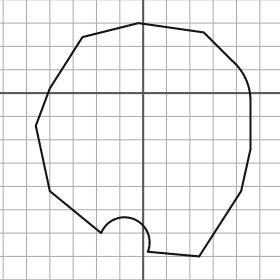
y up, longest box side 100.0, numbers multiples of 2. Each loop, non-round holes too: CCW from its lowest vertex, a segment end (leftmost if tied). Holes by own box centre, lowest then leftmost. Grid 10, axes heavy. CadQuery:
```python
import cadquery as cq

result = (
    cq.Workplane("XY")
    .moveTo(24.0, -70.0)
    .lineTo(42.0, -42.0)
    .lineTo(46.0, -24.0)
    .lineTo(46.0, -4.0)
    .threePointArc((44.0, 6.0), (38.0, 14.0))
    .lineTo(26.0, 26.0)
    .lineTo(-2.0, 30.0)
    .lineTo(-26.0, 24.0)
    .lineTo(-40.0, 2.0)
    .lineTo(-46.0, -14.0)
    .lineTo(-40.0, -42.0)
    .lineTo(-18.0, -60.0)
    .threePointArc((-4.0, -54.0), (2.0, -68.0))
    .close()
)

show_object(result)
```